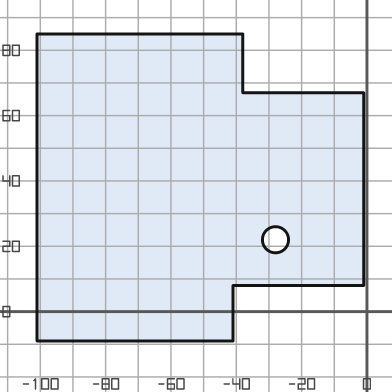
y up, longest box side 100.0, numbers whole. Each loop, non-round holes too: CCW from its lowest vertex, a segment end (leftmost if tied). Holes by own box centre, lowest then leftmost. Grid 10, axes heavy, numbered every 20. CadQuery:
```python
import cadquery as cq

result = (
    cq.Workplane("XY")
    .moveTo(-101.0, -9.0)
    .lineTo(-41.0, -9.0)
    .lineTo(-41.0, 8.0)
    .lineTo(-1.0, 8.0)
    .lineTo(-1.0, 67.0)
    .lineTo(-38.0, 67.0)
    .lineTo(-38.0, 85.0)
    .lineTo(-101.0, 85.0)
    .close()
    .moveTo(-28.0, 22.0)
    .circle(4.0)
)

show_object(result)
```